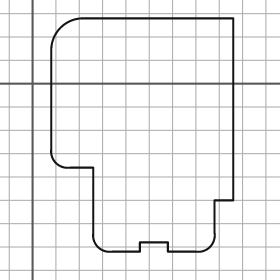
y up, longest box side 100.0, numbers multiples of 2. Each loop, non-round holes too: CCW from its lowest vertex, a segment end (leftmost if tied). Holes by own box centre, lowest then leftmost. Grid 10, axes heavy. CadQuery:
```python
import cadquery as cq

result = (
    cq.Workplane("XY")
    .moveTo(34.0, -72.0)
    .lineTo(46.0, -72.0)
    .lineTo(46.0, -68.0)
    .lineTo(58.0, -68.0)
    .lineTo(58.0, -72.0)
    .lineTo(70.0, -72.0)
    .threePointArc((76.0, -70.0), (78.0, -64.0))
    .lineTo(78.0, -50.0)
    .lineTo(86.0, -50.0)
    .lineTo(86.0, 28.0)
    .lineTo(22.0, 28.0)
    .threePointArc((12.0, 24.0), (8.0, 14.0))
    .lineTo(8.0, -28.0)
    .threePointArc((10.0, -34.0), (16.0, -36.0))
    .lineTo(26.0, -36.0)
    .lineTo(26.0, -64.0)
    .threePointArc((28.0, -70.0), (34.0, -72.0))
    .close()
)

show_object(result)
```